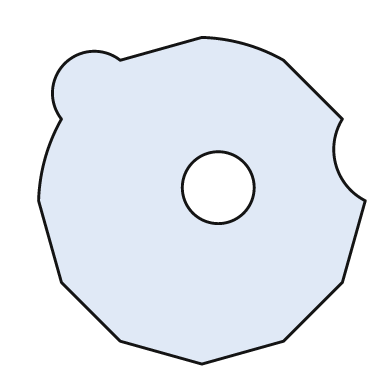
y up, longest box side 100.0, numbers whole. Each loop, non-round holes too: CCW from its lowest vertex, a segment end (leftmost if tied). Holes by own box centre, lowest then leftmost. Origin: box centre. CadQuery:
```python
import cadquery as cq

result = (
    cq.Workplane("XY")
    .moveTo(0.0, -50.0)
    .lineTo(25.0, -43.0)
    .lineTo(43.0, -25.0)
    .lineTo(50.0, 0.0)
    .threePointArc((41.0, 11.0), (43.0, 25.0))
    .lineTo(25.0, 43.0)
    .threePointArc((13.0, 48.0), (0.0, 50.0))
    .lineTo(-25.0, 43.0)
    .threePointArc((-42.0, 42.0), (-43.0, 25.0))
    .threePointArc((-48.0, 13.0), (-50.0, 0.0))
    .lineTo(-43.0, -25.0)
    .lineTo(-25.0, -43.0)
    .close()
    .moveTo(5.0, 4.0)
    .circle(11.0)
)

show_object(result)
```